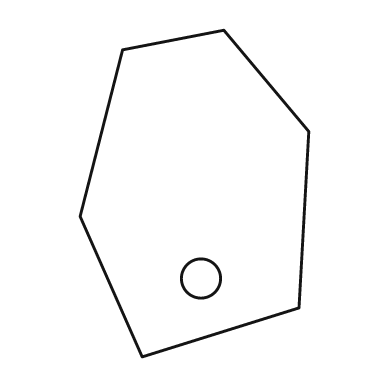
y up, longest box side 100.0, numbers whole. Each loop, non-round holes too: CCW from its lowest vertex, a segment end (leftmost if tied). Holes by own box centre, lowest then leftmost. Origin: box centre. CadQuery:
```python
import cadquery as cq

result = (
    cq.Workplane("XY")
    .moveTo(-16.0, -50.0)
    .lineTo(32.0, -35.0)
    .lineTo(35.0, 19.0)
    .lineTo(9.0, 50.0)
    .lineTo(-22.0, 44.0)
    .lineTo(-35.0, -7.0)
    .close()
    .moveTo(2.0, -26.0)
    .circle(6.0)
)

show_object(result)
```